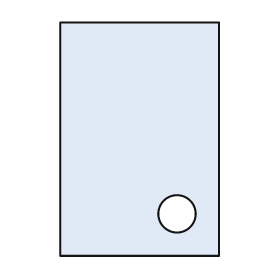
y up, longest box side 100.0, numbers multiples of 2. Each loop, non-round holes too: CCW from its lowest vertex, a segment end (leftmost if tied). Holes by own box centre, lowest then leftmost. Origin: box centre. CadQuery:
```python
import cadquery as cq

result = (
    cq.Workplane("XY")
    .moveTo(-34.0, -50.0)
    .lineTo(34.0, -50.0)
    .lineTo(34.0, 50.0)
    .lineTo(-34.0, 50.0)
    .close()
    .moveTo(16.0, -32.0)
    .circle(8.0)
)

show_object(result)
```